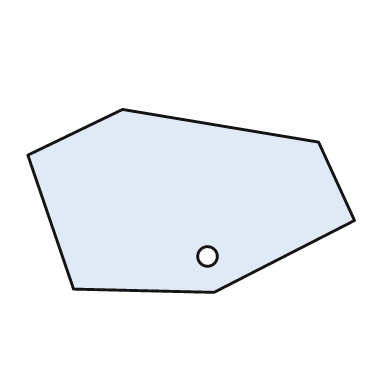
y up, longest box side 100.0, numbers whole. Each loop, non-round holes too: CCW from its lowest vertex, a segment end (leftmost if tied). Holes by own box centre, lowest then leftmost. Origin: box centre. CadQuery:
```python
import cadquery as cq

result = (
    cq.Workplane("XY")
    .moveTo(7.0, -28.0)
    .lineTo(50.0, -6.0)
    .lineTo(39.0, 18.0)
    .lineTo(-21.0, 28.0)
    .lineTo(-50.0, 14.0)
    .lineTo(-36.0, -27.0)
    .close()
    .moveTo(5.0, -17.0)
    .circle(3.0)
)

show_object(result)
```